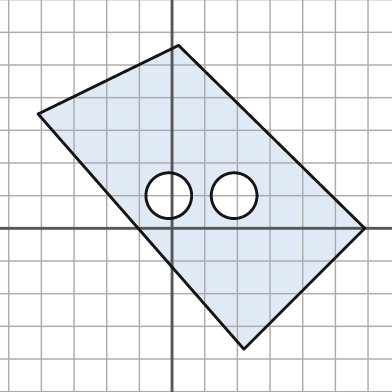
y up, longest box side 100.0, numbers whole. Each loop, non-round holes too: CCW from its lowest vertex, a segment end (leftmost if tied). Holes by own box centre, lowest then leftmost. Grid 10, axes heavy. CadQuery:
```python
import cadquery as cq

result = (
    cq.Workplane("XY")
    .moveTo(22.0, -37.0)
    .lineTo(59.0, 0.0)
    .lineTo(2.0, 56.0)
    .lineTo(-41.0, 35.0)
    .close()
    .moveTo(-1.0, 10.0)
    .circle(7.0)
    .moveTo(19.0, 10.0)
    .circle(7.0)
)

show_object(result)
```